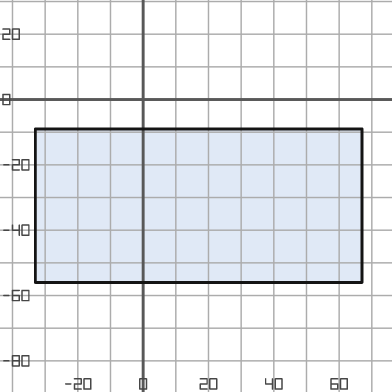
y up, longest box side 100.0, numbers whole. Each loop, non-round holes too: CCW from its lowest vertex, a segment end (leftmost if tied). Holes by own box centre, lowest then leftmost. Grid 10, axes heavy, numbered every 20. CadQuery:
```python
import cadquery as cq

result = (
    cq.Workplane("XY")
    .moveTo(-33.0, -56.0)
    .lineTo(67.0, -56.0)
    .lineTo(67.0, -9.0)
    .lineTo(-33.0, -9.0)
    .close()
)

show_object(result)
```